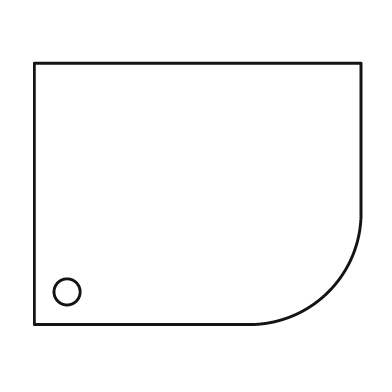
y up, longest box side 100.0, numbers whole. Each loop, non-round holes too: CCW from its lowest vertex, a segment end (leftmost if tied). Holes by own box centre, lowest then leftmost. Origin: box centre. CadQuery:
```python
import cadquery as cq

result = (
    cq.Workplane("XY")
    .moveTo(-50.0, -40.0)
    .lineTo(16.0, -40.0)
    .threePointArc((40.0, -30.0), (50.0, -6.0))
    .lineTo(50.0, 40.0)
    .lineTo(-50.0, 40.0)
    .close()
    .moveTo(-40.0, -30.0)
    .circle(4.0)
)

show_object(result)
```